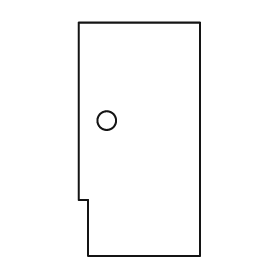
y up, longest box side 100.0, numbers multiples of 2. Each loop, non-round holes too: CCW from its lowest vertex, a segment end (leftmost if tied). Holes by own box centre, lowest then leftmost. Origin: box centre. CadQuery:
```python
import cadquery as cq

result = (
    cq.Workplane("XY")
    .moveTo(-22.0, -50.0)
    .lineTo(26.0, -50.0)
    .lineTo(26.0, 50.0)
    .lineTo(-26.0, 50.0)
    .lineTo(-26.0, -26.0)
    .lineTo(-22.0, -26.0)
    .close()
    .moveTo(-14.0, 8.0)
    .circle(4.0)
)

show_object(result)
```